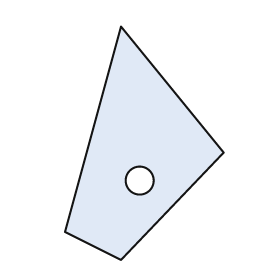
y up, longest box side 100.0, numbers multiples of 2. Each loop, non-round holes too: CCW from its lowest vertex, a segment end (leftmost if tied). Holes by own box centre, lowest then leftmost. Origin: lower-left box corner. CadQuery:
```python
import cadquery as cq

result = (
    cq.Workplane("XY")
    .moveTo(24.0, 0.0)
    .lineTo(68.0, 46.0)
    .lineTo(24.0, 100.0)
    .lineTo(0.0, 12.0)
    .close()
    .moveTo(32.0, 34.0)
    .circle(6.0)
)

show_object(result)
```